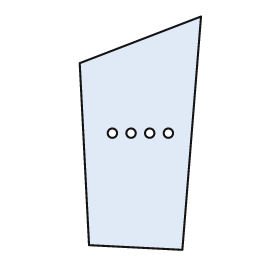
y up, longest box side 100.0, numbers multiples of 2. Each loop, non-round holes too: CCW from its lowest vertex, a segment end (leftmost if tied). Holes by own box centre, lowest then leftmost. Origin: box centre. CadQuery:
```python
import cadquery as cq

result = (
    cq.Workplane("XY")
    .moveTo(18.0, -50.0)
    .lineTo(26.0, 50.0)
    .lineTo(-26.0, 30.0)
    .lineTo(-22.0, -48.0)
    .close()
    .moveTo(-12.0, 0.0)
    .circle(2.0)
    .moveTo(-4.0, 0.0)
    .circle(2.0)
    .moveTo(4.0, 0.0)
    .circle(2.0)
    .moveTo(12.0, 0.0)
    .circle(2.0)
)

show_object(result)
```